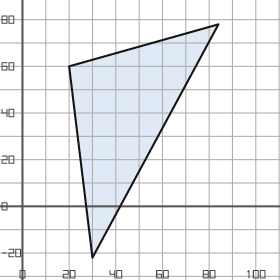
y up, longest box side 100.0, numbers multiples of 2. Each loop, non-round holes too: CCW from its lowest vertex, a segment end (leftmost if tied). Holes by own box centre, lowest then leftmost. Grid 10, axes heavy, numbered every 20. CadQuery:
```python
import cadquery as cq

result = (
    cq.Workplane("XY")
    .moveTo(30.0, -22.0)
    .lineTo(84.0, 78.0)
    .lineTo(20.0, 60.0)
    .close()
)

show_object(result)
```